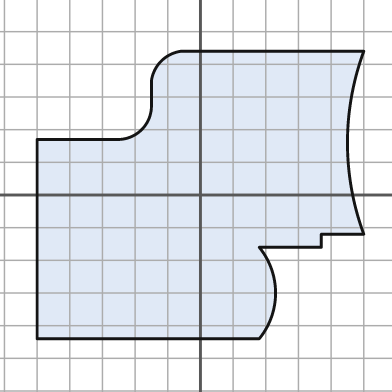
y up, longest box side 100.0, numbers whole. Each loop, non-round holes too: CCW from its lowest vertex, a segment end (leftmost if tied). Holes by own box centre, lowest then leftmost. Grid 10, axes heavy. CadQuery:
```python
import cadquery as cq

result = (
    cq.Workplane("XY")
    .moveTo(-50.0, -44.0)
    .lineTo(18.0, -44.0)
    .threePointArc((23.0, -30.0), (18.0, -16.0))
    .lineTo(37.0, -16.0)
    .lineTo(37.0, -12.0)
    .lineTo(50.0, -12.0)
    .threePointArc((45.0, 16.0), (50.0, 44.0))
    .lineTo(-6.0, 44.0)
    .threePointArc((-12.0, 41.0), (-15.0, 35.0))
    .lineTo(-15.0, 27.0)
    .threePointArc((-18.0, 20.0), (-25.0, 17.0))
    .lineTo(-50.0, 17.0)
    .close()
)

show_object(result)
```